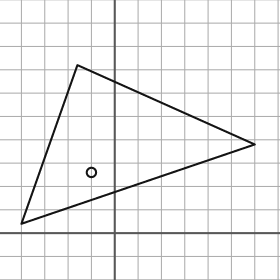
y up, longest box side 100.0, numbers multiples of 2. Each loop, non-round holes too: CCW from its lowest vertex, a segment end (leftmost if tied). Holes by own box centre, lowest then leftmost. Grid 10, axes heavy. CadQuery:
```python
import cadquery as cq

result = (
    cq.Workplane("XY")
    .moveTo(-40.0, 4.0)
    .lineTo(60.0, 38.0)
    .lineTo(-16.0, 72.0)
    .close()
    .moveTo(-10.0, 26.0)
    .circle(2.0)
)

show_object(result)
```